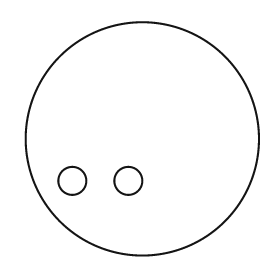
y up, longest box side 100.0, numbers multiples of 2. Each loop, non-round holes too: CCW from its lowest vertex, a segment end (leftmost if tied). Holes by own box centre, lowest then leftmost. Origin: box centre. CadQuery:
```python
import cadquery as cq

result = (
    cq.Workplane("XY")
    .moveTo(0.0, 0.0)
    .circle(50.0)
    .moveTo(-30.0, -18.0)
    .circle(6.0)
    .moveTo(-6.0, -18.0)
    .circle(6.0)
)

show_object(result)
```